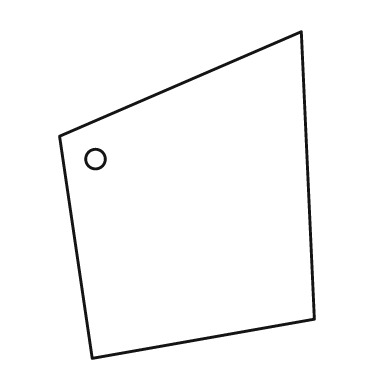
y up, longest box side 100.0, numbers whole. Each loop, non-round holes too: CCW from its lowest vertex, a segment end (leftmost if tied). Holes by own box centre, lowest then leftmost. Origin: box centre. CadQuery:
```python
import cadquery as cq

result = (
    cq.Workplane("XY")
    .moveTo(-29.0, -50.0)
    .lineTo(39.0, -38.0)
    .lineTo(35.0, 50.0)
    .lineTo(-39.0, 18.0)
    .close()
    .moveTo(-28.0, 11.0)
    .circle(3.0)
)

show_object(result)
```